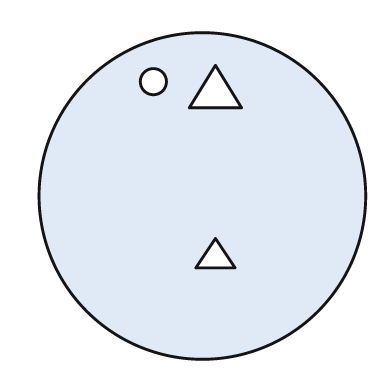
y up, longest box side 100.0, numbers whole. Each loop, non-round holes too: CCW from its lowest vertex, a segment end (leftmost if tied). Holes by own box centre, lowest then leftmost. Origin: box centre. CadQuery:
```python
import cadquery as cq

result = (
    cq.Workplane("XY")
    .moveTo(0.0, 0.0)
    .circle(50.0)
    .moveTo(-2.0, -22.0)
    .lineTo(10.0, -22.0)
    .lineTo(4.0, -13.0)
    .close()
    .moveTo(-4.0, 27.0)
    .lineTo(12.0, 27.0)
    .lineTo(4.0, 40.0)
    .close()
    .moveTo(-15.0, 35.0)
    .circle(4.0)
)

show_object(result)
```